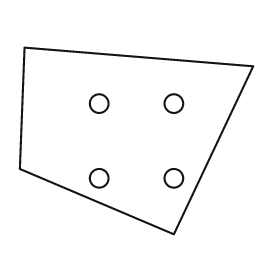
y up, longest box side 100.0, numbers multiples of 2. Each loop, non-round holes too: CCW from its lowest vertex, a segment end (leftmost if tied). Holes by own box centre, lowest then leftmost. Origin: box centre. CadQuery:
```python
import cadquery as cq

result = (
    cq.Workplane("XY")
    .moveTo(16.0, -40.0)
    .lineTo(50.0, 32.0)
    .lineTo(-48.0, 40.0)
    .lineTo(-50.0, -12.0)
    .close()
    .moveTo(-16.0, -16.0)
    .circle(4.0)
    .moveTo(16.0, -16.0)
    .circle(4.0)
    .moveTo(-16.0, 16.0)
    .circle(4.0)
    .moveTo(16.0, 16.0)
    .circle(4.0)
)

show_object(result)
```